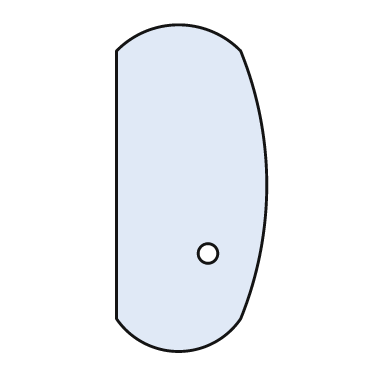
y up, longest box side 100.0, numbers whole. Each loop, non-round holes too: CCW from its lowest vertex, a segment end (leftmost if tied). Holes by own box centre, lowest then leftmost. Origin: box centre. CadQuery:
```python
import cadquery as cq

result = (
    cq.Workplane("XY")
    .moveTo(-23.0, -40.0)
    .threePointArc((-4.0, -50.0), (15.0, -40.0))
    .threePointArc((23.0, 1.0), (15.0, 42.0))
    .threePointArc((-4.0, 50.0), (-23.0, 42.0))
    .close()
    .moveTo(5.0, -20.0)
    .circle(3.0)
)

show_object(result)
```